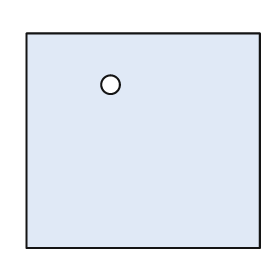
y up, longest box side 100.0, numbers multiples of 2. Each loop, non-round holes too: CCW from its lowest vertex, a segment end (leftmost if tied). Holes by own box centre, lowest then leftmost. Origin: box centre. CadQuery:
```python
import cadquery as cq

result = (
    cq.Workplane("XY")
    .moveTo(-50.0, -46.0)
    .lineTo(50.0, -46.0)
    .lineTo(50.0, 46.0)
    .lineTo(-50.0, 46.0)
    .close()
    .moveTo(-14.0, 24.0)
    .circle(4.0)
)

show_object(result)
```